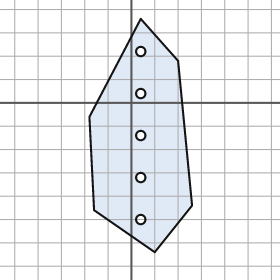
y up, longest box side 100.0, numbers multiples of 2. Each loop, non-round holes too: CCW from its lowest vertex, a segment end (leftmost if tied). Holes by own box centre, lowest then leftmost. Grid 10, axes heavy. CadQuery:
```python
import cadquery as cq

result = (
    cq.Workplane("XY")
    .moveTo(10.0, -64.0)
    .lineTo(26.0, -44.0)
    .lineTo(20.0, 18.0)
    .lineTo(4.0, 36.0)
    .lineTo(-18.0, -6.0)
    .lineTo(-16.0, -46.0)
    .close()
    .moveTo(4.0, -50.0)
    .circle(2.0)
    .moveTo(4.0, -32.0)
    .circle(2.0)
    .moveTo(4.0, -14.0)
    .circle(2.0)
    .moveTo(4.0, 4.0)
    .circle(2.0)
    .moveTo(4.0, 22.0)
    .circle(2.0)
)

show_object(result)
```